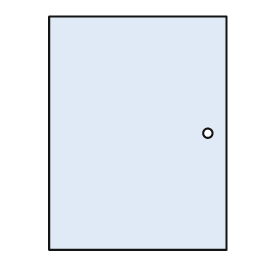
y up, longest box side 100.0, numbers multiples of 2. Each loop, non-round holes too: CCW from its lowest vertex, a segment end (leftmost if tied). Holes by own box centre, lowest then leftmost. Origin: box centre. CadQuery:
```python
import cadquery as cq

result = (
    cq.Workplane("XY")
    .moveTo(-38.0, -50.0)
    .lineTo(38.0, -50.0)
    .lineTo(38.0, 50.0)
    .lineTo(-38.0, 50.0)
    .close()
    .moveTo(30.0, 0.0)
    .circle(2.0)
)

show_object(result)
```